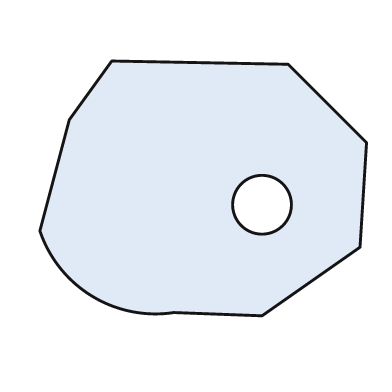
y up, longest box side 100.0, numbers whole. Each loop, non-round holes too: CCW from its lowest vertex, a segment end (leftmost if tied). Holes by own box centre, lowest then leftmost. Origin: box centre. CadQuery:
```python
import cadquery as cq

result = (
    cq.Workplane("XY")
    .moveTo(18.0, -39.0)
    .lineTo(48.0, -18.0)
    .lineTo(50.0, 14.0)
    .lineTo(26.0, 38.0)
    .lineTo(-28.0, 39.0)
    .lineTo(-41.0, 21.0)
    .lineTo(-50.0, -13.0)
    .threePointArc((-34.0, -33.0), (-9.0, -38.0))
    .close()
    .moveTo(18.0, -5.0)
    .circle(9.0)
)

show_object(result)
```